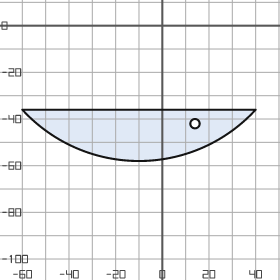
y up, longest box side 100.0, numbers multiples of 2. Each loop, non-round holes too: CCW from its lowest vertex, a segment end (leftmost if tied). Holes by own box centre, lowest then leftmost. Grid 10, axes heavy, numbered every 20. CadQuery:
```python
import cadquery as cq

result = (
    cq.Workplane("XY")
    .moveTo(-60.0, -36.0)
    .threePointArc((-10.0, -58.0), (40.0, -36.0))
    .close()
    .moveTo(14.0, -42.0)
    .circle(2.0)
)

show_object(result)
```